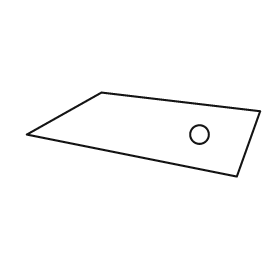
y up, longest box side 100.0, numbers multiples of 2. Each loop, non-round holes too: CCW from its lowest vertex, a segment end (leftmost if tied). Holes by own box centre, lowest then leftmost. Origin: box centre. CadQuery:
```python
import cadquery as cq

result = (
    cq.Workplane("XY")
    .moveTo(40.0, -18.0)
    .lineTo(50.0, 10.0)
    .lineTo(-18.0, 18.0)
    .lineTo(-50.0, 0.0)
    .close()
    .moveTo(24.0, 0.0)
    .circle(4.0)
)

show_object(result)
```